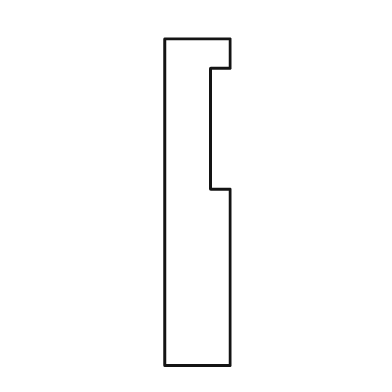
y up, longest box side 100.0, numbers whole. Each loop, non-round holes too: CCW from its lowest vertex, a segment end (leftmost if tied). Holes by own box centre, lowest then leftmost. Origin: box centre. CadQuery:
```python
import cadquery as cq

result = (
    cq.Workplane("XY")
    .moveTo(-10.0, -50.0)
    .lineTo(10.0, -50.0)
    .lineTo(10.0, 4.0)
    .lineTo(4.0, 4.0)
    .lineTo(4.0, 41.0)
    .lineTo(10.0, 41.0)
    .lineTo(10.0, 50.0)
    .lineTo(-10.0, 50.0)
    .close()
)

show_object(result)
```